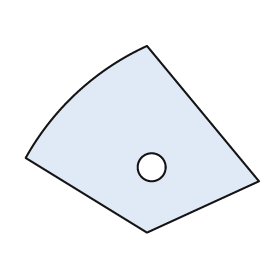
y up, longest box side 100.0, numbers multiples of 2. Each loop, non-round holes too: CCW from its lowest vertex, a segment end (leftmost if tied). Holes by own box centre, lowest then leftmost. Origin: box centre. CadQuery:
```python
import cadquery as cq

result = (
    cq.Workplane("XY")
    .moveTo(2.0, -40.0)
    .lineTo(50.0, -18.0)
    .lineTo(2.0, 40.0)
    .threePointArc((-28.0, 20.0), (-50.0, -8.0))
    .close()
    .moveTo(4.0, -12.0)
    .circle(6.0)
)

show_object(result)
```